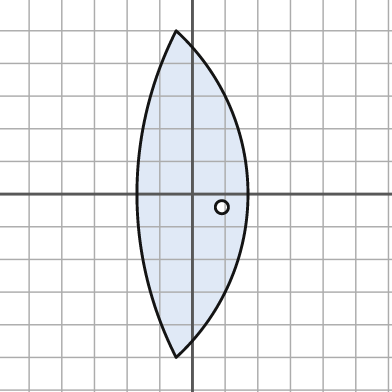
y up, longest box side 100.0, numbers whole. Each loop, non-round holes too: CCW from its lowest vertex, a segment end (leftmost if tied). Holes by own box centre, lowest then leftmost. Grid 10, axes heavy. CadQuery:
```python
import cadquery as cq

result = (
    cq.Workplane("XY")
    .moveTo(-5.0, -50.0)
    .threePointArc((17.0, 0.0), (-5.0, 50.0))
    .threePointArc((-17.0, 0.0), (-5.0, -50.0))
    .close()
    .moveTo(9.0, -4.0)
    .circle(2.0)
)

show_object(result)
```